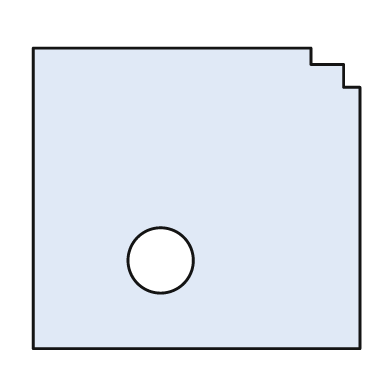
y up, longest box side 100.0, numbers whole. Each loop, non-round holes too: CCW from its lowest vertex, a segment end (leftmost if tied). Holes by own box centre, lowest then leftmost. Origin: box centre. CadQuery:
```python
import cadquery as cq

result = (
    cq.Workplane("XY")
    .moveTo(-50.0, -46.0)
    .lineTo(50.0, -46.0)
    .lineTo(50.0, 34.0)
    .lineTo(45.0, 34.0)
    .lineTo(45.0, 41.0)
    .lineTo(35.0, 41.0)
    .lineTo(35.0, 46.0)
    .lineTo(-50.0, 46.0)
    .close()
    .moveTo(-11.0, -19.0)
    .circle(10.0)
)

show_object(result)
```